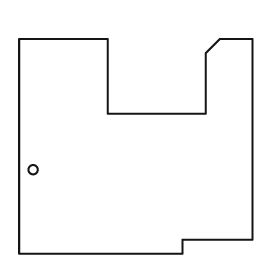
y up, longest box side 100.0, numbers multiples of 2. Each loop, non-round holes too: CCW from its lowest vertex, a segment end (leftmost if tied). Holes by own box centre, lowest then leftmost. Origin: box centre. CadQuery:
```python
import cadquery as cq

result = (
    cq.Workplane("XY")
    .moveTo(-50.0, -46.0)
    .lineTo(20.0, -46.0)
    .lineTo(20.0, -40.0)
    .lineTo(50.0, -40.0)
    .lineTo(50.0, 46.0)
    .lineTo(36.0, 46.0)
    .lineTo(30.0, 40.0)
    .lineTo(30.0, 14.0)
    .lineTo(-12.0, 14.0)
    .lineTo(-12.0, 46.0)
    .lineTo(-50.0, 46.0)
    .close()
    .moveTo(-44.0, -10.0)
    .circle(2.0)
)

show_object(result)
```